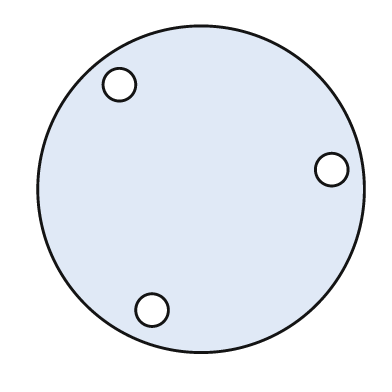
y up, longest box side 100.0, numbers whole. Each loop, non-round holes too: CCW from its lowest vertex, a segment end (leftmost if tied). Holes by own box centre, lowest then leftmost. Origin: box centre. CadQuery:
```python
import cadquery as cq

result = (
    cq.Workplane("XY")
    .moveTo(0.0, 0.0)
    .circle(50.0)
    .moveTo(-15.0, -37.0)
    .circle(5.0)
    .moveTo(40.0, 6.0)
    .circle(5.0)
    .moveTo(-25.0, 32.0)
    .circle(5.0)
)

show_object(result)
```